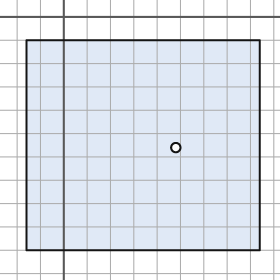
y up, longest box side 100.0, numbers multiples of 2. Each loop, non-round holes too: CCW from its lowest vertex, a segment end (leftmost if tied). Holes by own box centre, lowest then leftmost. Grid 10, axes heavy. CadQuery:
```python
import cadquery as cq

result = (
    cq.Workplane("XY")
    .moveTo(-16.0, -100.0)
    .lineTo(84.0, -100.0)
    .lineTo(84.0, -10.0)
    .lineTo(-16.0, -10.0)
    .close()
    .moveTo(48.0, -56.0)
    .circle(2.0)
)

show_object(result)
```